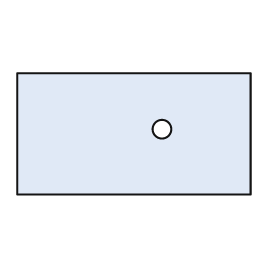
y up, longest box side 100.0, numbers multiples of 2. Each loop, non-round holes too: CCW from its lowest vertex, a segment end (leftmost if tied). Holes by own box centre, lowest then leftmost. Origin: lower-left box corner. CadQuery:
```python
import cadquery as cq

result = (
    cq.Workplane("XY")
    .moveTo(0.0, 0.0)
    .lineTo(100.0, 0.0)
    .lineTo(100.0, 52.0)
    .lineTo(0.0, 52.0)
    .close()
    .moveTo(62.0, 28.0)
    .circle(4.0)
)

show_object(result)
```